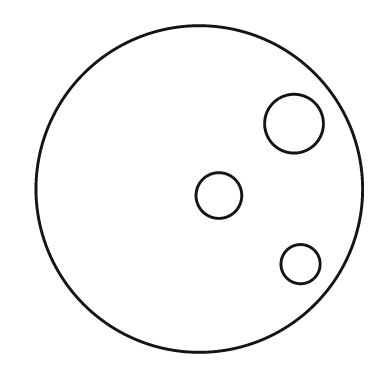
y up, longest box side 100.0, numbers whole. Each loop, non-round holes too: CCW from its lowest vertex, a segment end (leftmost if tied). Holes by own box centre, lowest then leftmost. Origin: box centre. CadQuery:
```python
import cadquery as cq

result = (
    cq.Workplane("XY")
    .moveTo(0.0, 0.0)
    .circle(50.0)
    .moveTo(31.0, -23.0)
    .circle(6.0)
    .moveTo(6.0, -2.0)
    .circle(7.0)
    .moveTo(29.0, 20.0)
    .circle(9.0)
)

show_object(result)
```